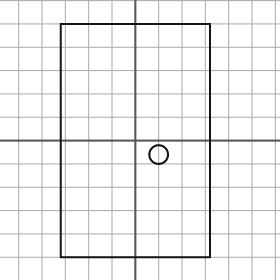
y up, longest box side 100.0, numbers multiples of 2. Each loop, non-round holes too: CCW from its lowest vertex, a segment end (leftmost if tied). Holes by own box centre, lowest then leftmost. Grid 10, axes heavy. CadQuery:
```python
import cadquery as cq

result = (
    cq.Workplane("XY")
    .moveTo(-32.0, -50.0)
    .lineTo(32.0, -50.0)
    .lineTo(32.0, 50.0)
    .lineTo(-32.0, 50.0)
    .close()
    .moveTo(10.0, -6.0)
    .circle(4.0)
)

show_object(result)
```